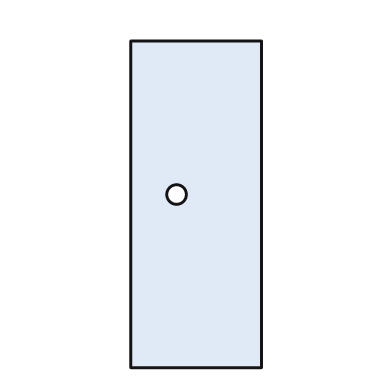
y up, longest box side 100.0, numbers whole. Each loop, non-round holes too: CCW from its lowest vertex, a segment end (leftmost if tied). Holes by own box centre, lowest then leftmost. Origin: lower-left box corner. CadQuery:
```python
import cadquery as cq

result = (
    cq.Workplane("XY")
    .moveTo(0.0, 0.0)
    .lineTo(40.0, 0.0)
    .lineTo(40.0, 100.0)
    .lineTo(0.0, 100.0)
    .close()
    .moveTo(14.0, 53.0)
    .circle(3.0)
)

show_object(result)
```